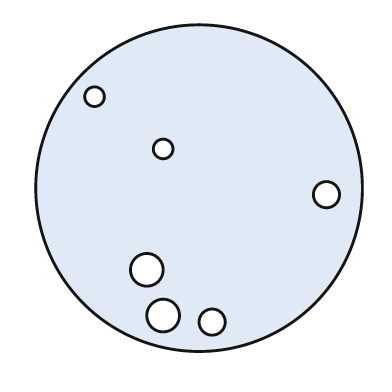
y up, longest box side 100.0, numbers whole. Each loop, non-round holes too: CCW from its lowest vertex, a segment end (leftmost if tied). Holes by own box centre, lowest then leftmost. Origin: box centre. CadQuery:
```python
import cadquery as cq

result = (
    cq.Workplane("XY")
    .moveTo(0.0, 0.0)
    .circle(50.0)
    .moveTo(4.0, -41.0)
    .circle(4.0)
    .moveTo(-11.0, -39.0)
    .circle(5.0)
    .moveTo(-16.0, -25.0)
    .circle(5.0)
    .moveTo(39.0, -2.0)
    .circle(4.0)
    .moveTo(-11.0, 12.0)
    .circle(3.0)
    .moveTo(-32.0, 28.0)
    .circle(3.0)
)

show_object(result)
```